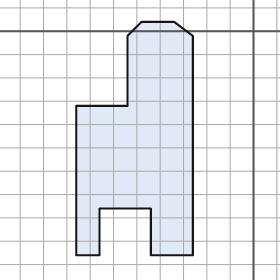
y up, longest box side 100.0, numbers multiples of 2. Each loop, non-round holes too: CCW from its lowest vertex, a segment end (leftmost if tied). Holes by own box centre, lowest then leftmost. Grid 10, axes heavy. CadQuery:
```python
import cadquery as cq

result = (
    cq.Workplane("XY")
    .moveTo(-76.0, -96.0)
    .lineTo(-66.0, -96.0)
    .lineTo(-66.0, -76.0)
    .lineTo(-44.0, -76.0)
    .lineTo(-44.0, -96.0)
    .lineTo(-26.0, -96.0)
    .lineTo(-26.0, -2.0)
    .lineTo(-34.0, 4.0)
    .lineTo(-48.0, 4.0)
    .lineTo(-54.0, -2.0)
    .lineTo(-54.0, -32.0)
    .lineTo(-76.0, -32.0)
    .close()
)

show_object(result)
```